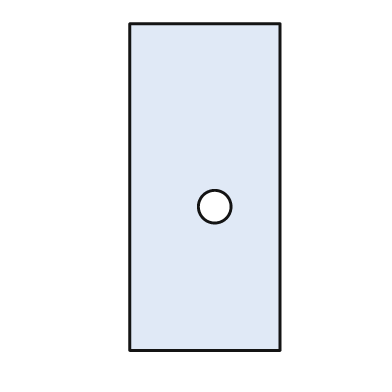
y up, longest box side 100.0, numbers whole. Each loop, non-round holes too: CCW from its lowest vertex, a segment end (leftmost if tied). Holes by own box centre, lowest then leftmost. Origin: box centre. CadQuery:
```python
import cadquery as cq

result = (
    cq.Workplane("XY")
    .moveTo(-23.0, -50.0)
    .lineTo(23.0, -50.0)
    .lineTo(23.0, 50.0)
    .lineTo(-23.0, 50.0)
    .close()
    .moveTo(3.0, -6.0)
    .circle(5.0)
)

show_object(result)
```